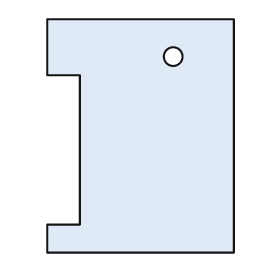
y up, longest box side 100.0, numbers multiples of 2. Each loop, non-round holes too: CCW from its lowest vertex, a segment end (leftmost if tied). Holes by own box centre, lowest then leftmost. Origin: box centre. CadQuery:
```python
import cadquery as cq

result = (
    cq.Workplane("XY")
    .moveTo(-40.0, -50.0)
    .lineTo(40.0, -50.0)
    .lineTo(40.0, 50.0)
    .lineTo(-40.0, 50.0)
    .lineTo(-40.0, 26.0)
    .lineTo(-26.0, 26.0)
    .lineTo(-26.0, -38.0)
    .lineTo(-40.0, -38.0)
    .close()
    .moveTo(14.0, 34.0)
    .circle(4.0)
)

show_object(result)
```